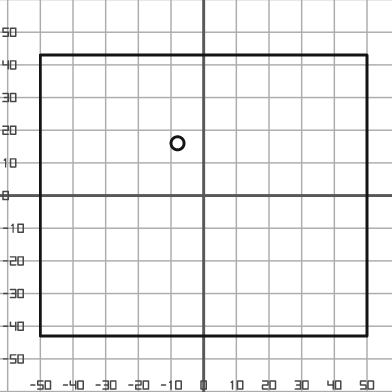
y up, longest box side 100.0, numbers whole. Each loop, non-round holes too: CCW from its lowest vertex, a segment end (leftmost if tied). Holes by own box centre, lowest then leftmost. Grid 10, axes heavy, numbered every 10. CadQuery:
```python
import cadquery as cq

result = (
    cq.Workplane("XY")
    .moveTo(-50.0, -43.0)
    .lineTo(50.0, -43.0)
    .lineTo(50.0, 43.0)
    .lineTo(-50.0, 43.0)
    .close()
    .moveTo(-8.0, 16.0)
    .circle(2.0)
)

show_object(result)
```